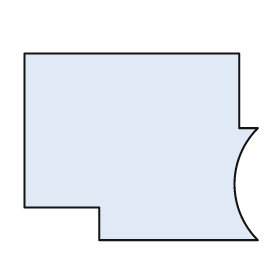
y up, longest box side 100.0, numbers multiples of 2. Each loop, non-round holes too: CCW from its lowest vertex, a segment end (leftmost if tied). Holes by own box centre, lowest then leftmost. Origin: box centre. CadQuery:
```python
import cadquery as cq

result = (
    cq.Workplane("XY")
    .moveTo(-18.0, -40.0)
    .lineTo(50.0, -40.0)
    .threePointArc((40.0, -16.0), (50.0, 8.0))
    .lineTo(42.0, 8.0)
    .lineTo(42.0, 40.0)
    .lineTo(-50.0, 40.0)
    .lineTo(-50.0, -26.0)
    .lineTo(-18.0, -26.0)
    .close()
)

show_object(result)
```